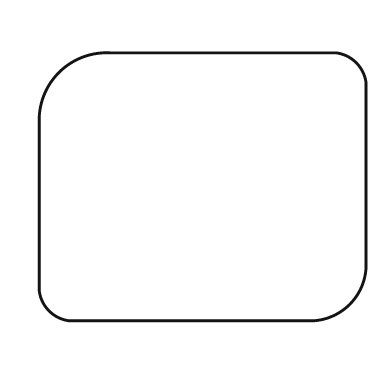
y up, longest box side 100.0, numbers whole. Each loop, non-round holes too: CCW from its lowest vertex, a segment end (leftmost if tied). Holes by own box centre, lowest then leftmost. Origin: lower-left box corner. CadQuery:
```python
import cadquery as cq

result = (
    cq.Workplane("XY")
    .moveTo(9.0, 0.0)
    .lineTo(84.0, 0.0)
    .threePointArc((95.0, 5.0), (100.0, 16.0))
    .lineTo(100.0, 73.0)
    .threePointArc((97.0, 79.0), (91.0, 82.0))
    .lineTo(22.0, 82.0)
    .threePointArc((6.0, 76.0), (0.0, 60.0))
    .lineTo(0.0, 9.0)
    .threePointArc((3.0, 3.0), (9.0, 0.0))
    .close()
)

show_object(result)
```